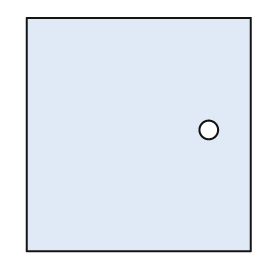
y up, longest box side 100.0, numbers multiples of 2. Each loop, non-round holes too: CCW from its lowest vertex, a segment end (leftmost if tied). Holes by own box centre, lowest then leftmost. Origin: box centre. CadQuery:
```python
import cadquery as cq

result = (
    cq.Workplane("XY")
    .moveTo(-48.0, -50.0)
    .lineTo(48.0, -50.0)
    .lineTo(48.0, 50.0)
    .lineTo(-48.0, 50.0)
    .close()
    .moveTo(30.0, 2.0)
    .circle(4.0)
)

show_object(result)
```